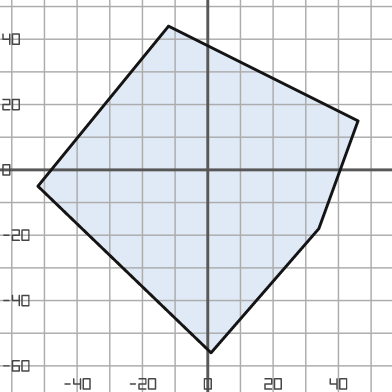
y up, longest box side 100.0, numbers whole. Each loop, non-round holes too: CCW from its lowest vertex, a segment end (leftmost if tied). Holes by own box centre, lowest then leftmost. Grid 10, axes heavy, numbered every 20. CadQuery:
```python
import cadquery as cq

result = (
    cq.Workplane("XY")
    .moveTo(1.0, -56.0)
    .lineTo(34.0, -18.0)
    .lineTo(46.0, 15.0)
    .lineTo(-12.0, 44.0)
    .lineTo(-52.0, -5.0)
    .close()
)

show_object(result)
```